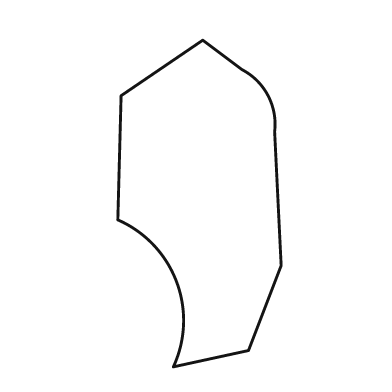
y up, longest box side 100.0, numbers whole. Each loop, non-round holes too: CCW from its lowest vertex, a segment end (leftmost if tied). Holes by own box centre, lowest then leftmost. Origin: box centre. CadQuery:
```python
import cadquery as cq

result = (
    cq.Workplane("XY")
    .moveTo(-8.0, -50.0)
    .lineTo(15.0, -45.0)
    .lineTo(25.0, -19.0)
    .lineTo(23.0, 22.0)
    .threePointArc((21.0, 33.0), (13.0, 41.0))
    .lineTo(1.0, 50.0)
    .lineTo(-24.0, 33.0)
    .lineTo(-25.0, -5.0)
    .threePointArc((-7.0, -24.0), (-8.0, -50.0))
    .close()
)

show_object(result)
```